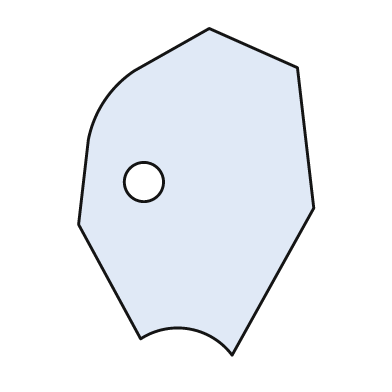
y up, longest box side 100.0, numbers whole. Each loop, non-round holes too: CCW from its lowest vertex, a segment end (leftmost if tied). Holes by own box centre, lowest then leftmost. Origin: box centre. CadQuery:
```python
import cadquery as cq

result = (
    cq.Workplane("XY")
    .moveTo(11.0, -50.0)
    .lineTo(36.0, -5.0)
    .lineTo(31.0, 38.0)
    .lineTo(4.0, 50.0)
    .lineTo(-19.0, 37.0)
    .threePointArc((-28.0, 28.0), (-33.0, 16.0))
    .lineTo(-36.0, -10.0)
    .lineTo(-17.0, -45.0)
    .threePointArc((-2.0, -42.0), (11.0, -50.0))
    .close()
    .moveTo(-16.0, 3.0)
    .circle(6.0)
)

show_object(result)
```